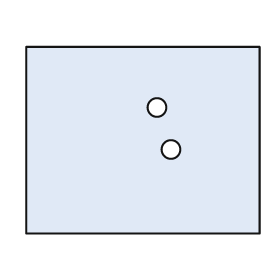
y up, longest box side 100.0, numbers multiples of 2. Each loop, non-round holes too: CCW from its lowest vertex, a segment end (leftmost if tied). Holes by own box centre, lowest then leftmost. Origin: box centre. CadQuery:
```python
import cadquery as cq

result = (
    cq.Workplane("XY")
    .moveTo(-50.0, -40.0)
    .lineTo(50.0, -40.0)
    .lineTo(50.0, 40.0)
    .lineTo(-50.0, 40.0)
    .close()
    .moveTo(12.0, -4.0)
    .circle(4.0)
    .moveTo(6.0, 14.0)
    .circle(4.0)
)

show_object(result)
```